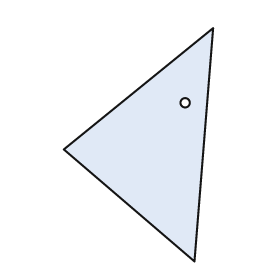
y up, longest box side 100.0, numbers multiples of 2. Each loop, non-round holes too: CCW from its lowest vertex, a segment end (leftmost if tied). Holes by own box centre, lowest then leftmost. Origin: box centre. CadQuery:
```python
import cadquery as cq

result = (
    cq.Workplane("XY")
    .moveTo(24.0, -50.0)
    .lineTo(32.0, 50.0)
    .lineTo(-32.0, -2.0)
    .close()
    .moveTo(20.0, 18.0)
    .circle(2.0)
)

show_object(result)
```